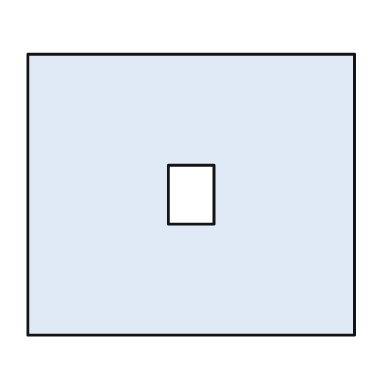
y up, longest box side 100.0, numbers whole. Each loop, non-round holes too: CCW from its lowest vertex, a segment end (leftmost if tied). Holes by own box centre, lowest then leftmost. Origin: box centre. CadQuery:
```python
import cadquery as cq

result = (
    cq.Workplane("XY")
    .moveTo(-50.0, -43.0)
    .lineTo(50.0, -43.0)
    .lineTo(50.0, 43.0)
    .lineTo(-50.0, 43.0)
    .close()
    .moveTo(-7.0, -9.0)
    .lineTo(7.0, -9.0)
    .lineTo(7.0, 9.0)
    .lineTo(-7.0, 9.0)
    .close()
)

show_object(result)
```